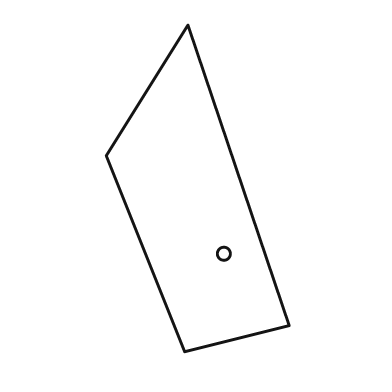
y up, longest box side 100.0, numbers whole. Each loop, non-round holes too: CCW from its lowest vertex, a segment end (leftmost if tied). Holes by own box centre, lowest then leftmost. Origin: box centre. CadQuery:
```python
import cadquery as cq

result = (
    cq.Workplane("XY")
    .moveTo(-4.0, -50.0)
    .lineTo(28.0, -42.0)
    .lineTo(-3.0, 50.0)
    .lineTo(-28.0, 10.0)
    .close()
    .moveTo(8.0, -20.0)
    .circle(2.0)
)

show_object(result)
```